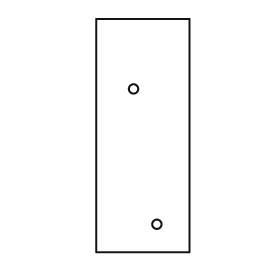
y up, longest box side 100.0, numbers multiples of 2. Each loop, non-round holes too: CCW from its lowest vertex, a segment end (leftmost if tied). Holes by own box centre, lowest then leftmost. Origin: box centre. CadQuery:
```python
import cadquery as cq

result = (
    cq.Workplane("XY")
    .moveTo(-20.0, -50.0)
    .lineTo(20.0, -50.0)
    .lineTo(20.0, 50.0)
    .lineTo(-20.0, 50.0)
    .close()
    .moveTo(6.0, -38.0)
    .circle(2.0)
    .moveTo(-4.0, 20.0)
    .circle(2.0)
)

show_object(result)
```